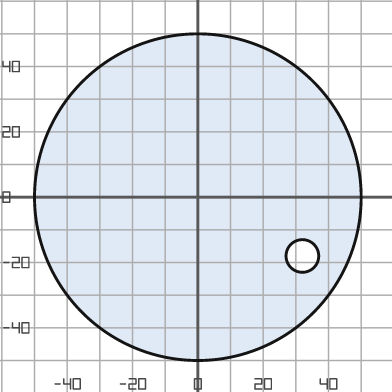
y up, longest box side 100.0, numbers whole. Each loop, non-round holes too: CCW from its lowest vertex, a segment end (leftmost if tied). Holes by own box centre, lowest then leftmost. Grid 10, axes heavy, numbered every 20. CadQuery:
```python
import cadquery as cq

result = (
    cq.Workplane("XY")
    .moveTo(0.0, 0.0)
    .circle(50.0)
    .moveTo(32.0, -18.0)
    .circle(5.0)
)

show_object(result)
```